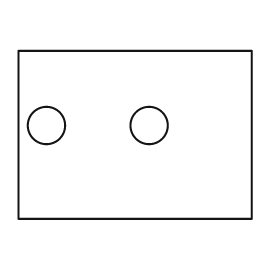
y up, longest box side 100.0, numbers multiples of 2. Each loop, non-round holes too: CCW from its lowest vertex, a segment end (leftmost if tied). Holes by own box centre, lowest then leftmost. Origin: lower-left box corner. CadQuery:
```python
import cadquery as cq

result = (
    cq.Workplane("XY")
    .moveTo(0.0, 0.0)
    .lineTo(100.0, 0.0)
    .lineTo(100.0, 72.0)
    .lineTo(0.0, 72.0)
    .close()
    .moveTo(12.0, 40.0)
    .circle(8.0)
    .moveTo(56.0, 40.0)
    .circle(8.0)
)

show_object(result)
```